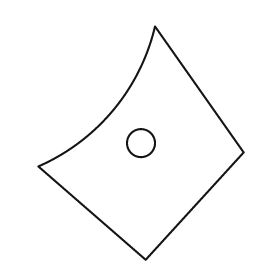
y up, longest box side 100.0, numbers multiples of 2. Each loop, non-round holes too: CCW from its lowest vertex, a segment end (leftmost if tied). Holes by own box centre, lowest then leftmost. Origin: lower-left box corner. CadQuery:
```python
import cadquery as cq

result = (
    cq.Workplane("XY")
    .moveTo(46.0, 0.0)
    .lineTo(88.0, 46.0)
    .lineTo(50.0, 100.0)
    .threePointArc((32.0, 64.0), (0.0, 40.0))
    .close()
    .moveTo(44.0, 50.0)
    .circle(6.0)
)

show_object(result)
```